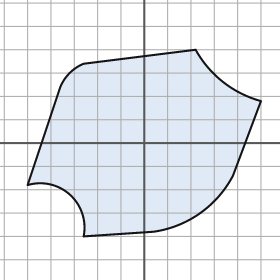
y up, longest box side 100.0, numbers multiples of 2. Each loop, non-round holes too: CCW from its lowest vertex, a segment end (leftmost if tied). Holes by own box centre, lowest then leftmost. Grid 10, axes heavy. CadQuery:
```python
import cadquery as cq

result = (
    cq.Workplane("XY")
    .moveTo(-26.0, -40.0)
    .lineTo(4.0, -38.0)
    .threePointArc((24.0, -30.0), (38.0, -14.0))
    .lineTo(50.0, 18.0)
    .threePointArc((34.0, 26.0), (22.0, 40.0))
    .lineTo(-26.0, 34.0)
    .threePointArc((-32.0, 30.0), (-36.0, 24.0))
    .lineTo(-50.0, -18.0)
    .threePointArc((-32.0, -22.0), (-26.0, -40.0))
    .close()
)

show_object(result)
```